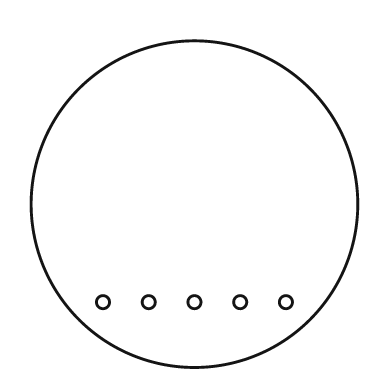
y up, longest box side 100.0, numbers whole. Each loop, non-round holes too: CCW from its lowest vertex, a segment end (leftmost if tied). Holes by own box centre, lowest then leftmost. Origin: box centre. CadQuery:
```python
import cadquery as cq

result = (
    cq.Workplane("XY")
    .moveTo(0.0, 0.0)
    .circle(50.0)
    .moveTo(-28.0, -30.0)
    .circle(2.0)
    .moveTo(-14.0, -30.0)
    .circle(2.0)
    .moveTo(0.0, -30.0)
    .circle(2.0)
    .moveTo(14.0, -30.0)
    .circle(2.0)
    .moveTo(28.0, -30.0)
    .circle(2.0)
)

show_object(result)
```